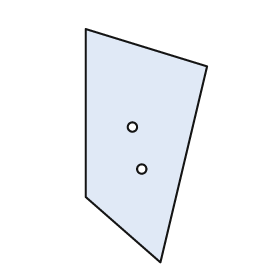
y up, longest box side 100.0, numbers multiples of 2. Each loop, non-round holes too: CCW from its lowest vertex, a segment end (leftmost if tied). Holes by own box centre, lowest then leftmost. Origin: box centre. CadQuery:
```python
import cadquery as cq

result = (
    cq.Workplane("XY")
    .moveTo(6.0, -50.0)
    .lineTo(26.0, 34.0)
    .lineTo(-26.0, 50.0)
    .lineTo(-26.0, -22.0)
    .close()
    .moveTo(-2.0, -10.0)
    .circle(2.0)
    .moveTo(-6.0, 8.0)
    .circle(2.0)
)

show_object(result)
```